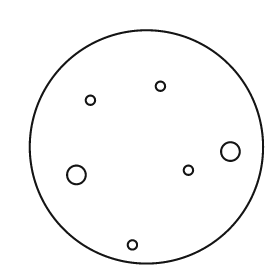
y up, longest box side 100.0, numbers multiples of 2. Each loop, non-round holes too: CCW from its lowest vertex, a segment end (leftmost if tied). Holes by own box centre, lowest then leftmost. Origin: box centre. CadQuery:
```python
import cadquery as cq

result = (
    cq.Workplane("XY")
    .moveTo(0.0, 0.0)
    .circle(50.0)
    .moveTo(-6.0, -42.0)
    .circle(2.0)
    .moveTo(-30.0, -12.0)
    .circle(4.0)
    .moveTo(18.0, -10.0)
    .circle(2.0)
    .moveTo(36.0, -2.0)
    .circle(4.0)
    .moveTo(-24.0, 20.0)
    .circle(2.0)
    .moveTo(6.0, 26.0)
    .circle(2.0)
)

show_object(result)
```